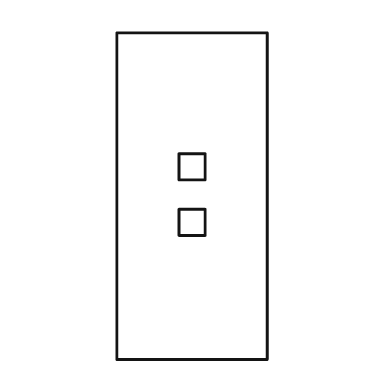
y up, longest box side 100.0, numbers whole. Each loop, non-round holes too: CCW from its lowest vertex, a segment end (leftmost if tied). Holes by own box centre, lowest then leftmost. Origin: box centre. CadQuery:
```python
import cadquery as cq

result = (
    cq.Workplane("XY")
    .moveTo(-23.0, -50.0)
    .lineTo(23.0, -50.0)
    .lineTo(23.0, 50.0)
    .lineTo(-23.0, 50.0)
    .close()
    .moveTo(-4.0, -12.0)
    .lineTo(4.0, -12.0)
    .lineTo(4.0, -4.0)
    .lineTo(-4.0, -4.0)
    .close()
    .moveTo(-4.0, 5.0)
    .lineTo(4.0, 5.0)
    .lineTo(4.0, 13.0)
    .lineTo(-4.0, 13.0)
    .close()
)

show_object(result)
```